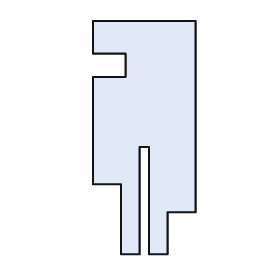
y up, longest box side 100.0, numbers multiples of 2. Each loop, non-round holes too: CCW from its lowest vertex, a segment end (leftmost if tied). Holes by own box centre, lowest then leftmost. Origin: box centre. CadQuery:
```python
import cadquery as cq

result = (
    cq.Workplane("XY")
    .moveTo(-10.0, -50.0)
    .lineTo(-2.0, -50.0)
    .lineTo(-2.0, -4.0)
    .lineTo(2.0, -4.0)
    .lineTo(2.0, -50.0)
    .lineTo(10.0, -50.0)
    .lineTo(10.0, -32.0)
    .lineTo(22.0, -32.0)
    .lineTo(22.0, 50.0)
    .lineTo(-22.0, 50.0)
    .lineTo(-22.0, 36.0)
    .lineTo(-8.0, 36.0)
    .lineTo(-8.0, 26.0)
    .lineTo(-22.0, 26.0)
    .lineTo(-22.0, -20.0)
    .lineTo(-10.0, -20.0)
    .close()
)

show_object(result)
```